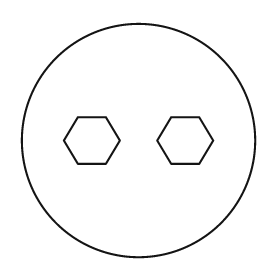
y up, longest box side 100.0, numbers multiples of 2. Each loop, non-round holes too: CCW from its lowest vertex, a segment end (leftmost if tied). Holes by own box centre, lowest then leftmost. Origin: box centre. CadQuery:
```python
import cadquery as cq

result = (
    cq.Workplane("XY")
    .moveTo(0.0, 0.0)
    .circle(50.0)
    .moveTo(-26.0, -10.0)
    .lineTo(-14.0, -10.0)
    .lineTo(-8.0, 0.0)
    .lineTo(-14.0, 10.0)
    .lineTo(-26.0, 10.0)
    .lineTo(-32.0, 0.0)
    .close()
    .moveTo(14.0, -10.0)
    .lineTo(26.0, -10.0)
    .lineTo(32.0, 0.0)
    .lineTo(26.0, 10.0)
    .lineTo(14.0, 10.0)
    .lineTo(8.0, 0.0)
    .close()
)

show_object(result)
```